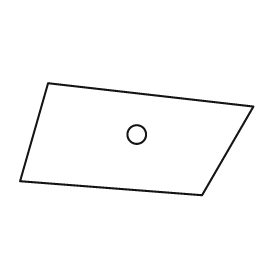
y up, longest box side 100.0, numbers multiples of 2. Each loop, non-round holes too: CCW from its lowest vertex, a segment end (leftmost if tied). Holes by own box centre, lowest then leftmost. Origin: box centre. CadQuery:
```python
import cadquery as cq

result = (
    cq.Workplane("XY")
    .moveTo(28.0, -24.0)
    .lineTo(50.0, 14.0)
    .lineTo(-38.0, 24.0)
    .lineTo(-50.0, -18.0)
    .close()
    .moveTo(0.0, 2.0)
    .circle(4.0)
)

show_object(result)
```